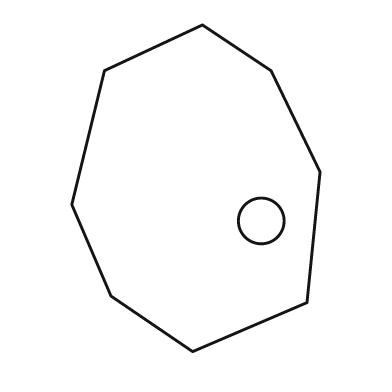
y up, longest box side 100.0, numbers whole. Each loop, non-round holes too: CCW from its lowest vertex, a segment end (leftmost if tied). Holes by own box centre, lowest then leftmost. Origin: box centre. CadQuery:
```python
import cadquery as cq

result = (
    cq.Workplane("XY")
    .moveTo(-1.0, -50.0)
    .lineTo(34.0, -35.0)
    .lineTo(38.0, 5.0)
    .lineTo(23.0, 36.0)
    .lineTo(2.0, 50.0)
    .lineTo(-28.0, 36.0)
    .lineTo(-38.0, -5.0)
    .lineTo(-26.0, -33.0)
    .close()
    .moveTo(20.0, -10.0)
    .circle(7.0)
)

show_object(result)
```